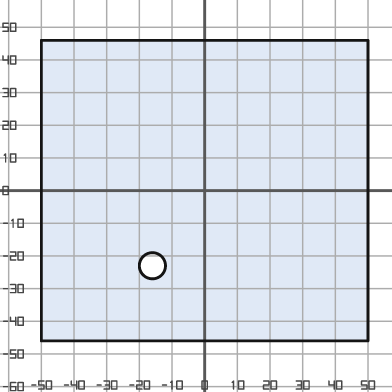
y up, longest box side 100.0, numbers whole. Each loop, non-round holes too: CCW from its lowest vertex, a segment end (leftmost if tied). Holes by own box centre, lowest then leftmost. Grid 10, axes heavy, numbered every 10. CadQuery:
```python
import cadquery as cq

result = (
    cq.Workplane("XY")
    .moveTo(-50.0, -46.0)
    .lineTo(50.0, -46.0)
    .lineTo(50.0, 46.0)
    .lineTo(-50.0, 46.0)
    .close()
    .moveTo(-16.0, -23.0)
    .circle(4.0)
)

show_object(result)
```